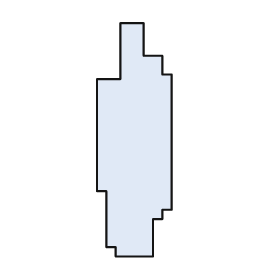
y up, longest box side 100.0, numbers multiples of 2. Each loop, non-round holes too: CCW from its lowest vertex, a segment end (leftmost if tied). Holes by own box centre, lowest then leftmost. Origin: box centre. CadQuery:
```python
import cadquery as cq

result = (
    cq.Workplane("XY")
    .moveTo(-8.0, -50.0)
    .lineTo(8.0, -50.0)
    .lineTo(8.0, -34.0)
    .lineTo(12.0, -34.0)
    .lineTo(12.0, -30.0)
    .lineTo(16.0, -30.0)
    .lineTo(16.0, 28.0)
    .lineTo(12.0, 28.0)
    .lineTo(12.0, 36.0)
    .lineTo(4.0, 36.0)
    .lineTo(4.0, 50.0)
    .lineTo(-6.0, 50.0)
    .lineTo(-6.0, 26.0)
    .lineTo(-16.0, 26.0)
    .lineTo(-16.0, -22.0)
    .lineTo(-12.0, -22.0)
    .lineTo(-12.0, -46.0)
    .lineTo(-8.0, -46.0)
    .close()
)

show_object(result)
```